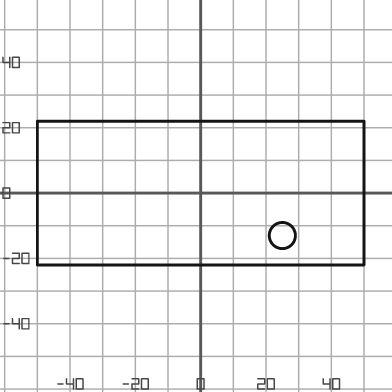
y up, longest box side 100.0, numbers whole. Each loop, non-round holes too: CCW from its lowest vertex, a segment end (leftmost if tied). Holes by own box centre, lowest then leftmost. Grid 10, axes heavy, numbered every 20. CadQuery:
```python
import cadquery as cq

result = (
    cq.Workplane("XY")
    .moveTo(-50.0, -22.0)
    .lineTo(50.0, -22.0)
    .lineTo(50.0, 22.0)
    .lineTo(-50.0, 22.0)
    .close()
    .moveTo(25.0, -13.0)
    .circle(4.0)
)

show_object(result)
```